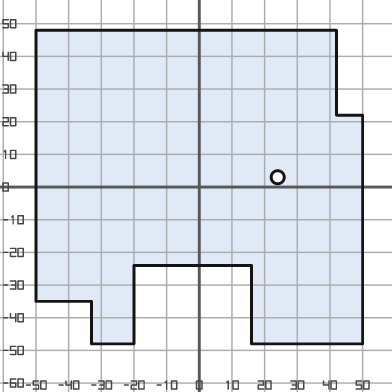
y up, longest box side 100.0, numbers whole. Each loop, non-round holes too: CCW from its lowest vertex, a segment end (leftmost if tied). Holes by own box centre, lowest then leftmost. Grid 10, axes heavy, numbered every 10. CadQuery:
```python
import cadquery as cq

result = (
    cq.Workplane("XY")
    .moveTo(-33.0, -48.0)
    .lineTo(-20.0, -48.0)
    .lineTo(-20.0, -24.0)
    .lineTo(16.0, -24.0)
    .lineTo(16.0, -48.0)
    .lineTo(50.0, -48.0)
    .lineTo(50.0, 22.0)
    .lineTo(42.0, 22.0)
    .lineTo(42.0, 48.0)
    .lineTo(-50.0, 48.0)
    .lineTo(-50.0, -35.0)
    .lineTo(-33.0, -35.0)
    .close()
    .moveTo(24.0, 3.0)
    .circle(2.0)
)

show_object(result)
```